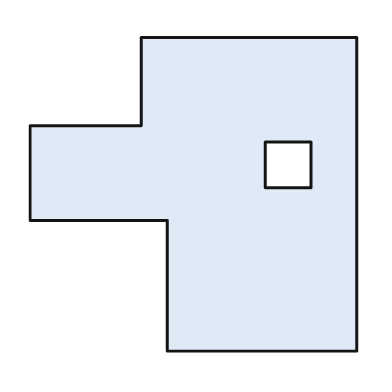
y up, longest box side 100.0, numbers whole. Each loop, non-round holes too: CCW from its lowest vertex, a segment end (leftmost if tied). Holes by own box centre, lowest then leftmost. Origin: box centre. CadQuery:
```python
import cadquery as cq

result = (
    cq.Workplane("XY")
    .moveTo(-8.0, -48.0)
    .lineTo(50.0, -48.0)
    .lineTo(50.0, 48.0)
    .lineTo(-16.0, 48.0)
    .lineTo(-16.0, 21.0)
    .lineTo(-50.0, 21.0)
    .lineTo(-50.0, -8.0)
    .lineTo(-8.0, -8.0)
    .close()
    .moveTo(22.0, 2.0)
    .lineTo(36.0, 2.0)
    .lineTo(36.0, 16.0)
    .lineTo(22.0, 16.0)
    .close()
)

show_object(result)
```